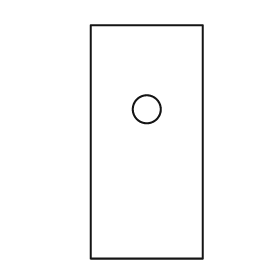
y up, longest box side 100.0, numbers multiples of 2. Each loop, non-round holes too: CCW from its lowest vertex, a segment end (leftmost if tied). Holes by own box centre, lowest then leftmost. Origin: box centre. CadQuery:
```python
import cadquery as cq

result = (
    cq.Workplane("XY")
    .moveTo(-24.0, -50.0)
    .lineTo(24.0, -50.0)
    .lineTo(24.0, 50.0)
    .lineTo(-24.0, 50.0)
    .close()
    .moveTo(0.0, 14.0)
    .circle(6.0)
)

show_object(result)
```